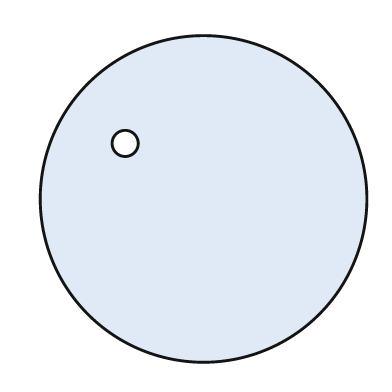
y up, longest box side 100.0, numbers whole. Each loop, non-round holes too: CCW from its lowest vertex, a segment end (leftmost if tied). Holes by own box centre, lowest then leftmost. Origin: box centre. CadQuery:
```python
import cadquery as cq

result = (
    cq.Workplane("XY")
    .moveTo(0.0, 0.0)
    .circle(50.0)
    .moveTo(-24.0, 17.0)
    .circle(4.0)
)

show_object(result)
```